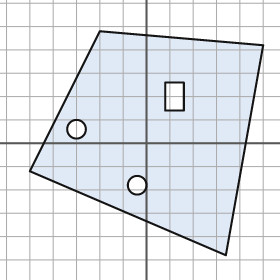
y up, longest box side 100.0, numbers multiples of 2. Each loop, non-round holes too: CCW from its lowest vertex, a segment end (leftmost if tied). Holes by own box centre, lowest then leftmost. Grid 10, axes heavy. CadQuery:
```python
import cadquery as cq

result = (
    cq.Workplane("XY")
    .moveTo(34.0, -48.0)
    .lineTo(50.0, 42.0)
    .lineTo(-20.0, 48.0)
    .lineTo(-50.0, -12.0)
    .close()
    .moveTo(-4.0, -18.0)
    .circle(4.0)
    .moveTo(-30.0, 6.0)
    .circle(4.0)
    .moveTo(8.0, 14.0)
    .lineTo(16.0, 14.0)
    .lineTo(16.0, 26.0)
    .lineTo(8.0, 26.0)
    .close()
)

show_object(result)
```